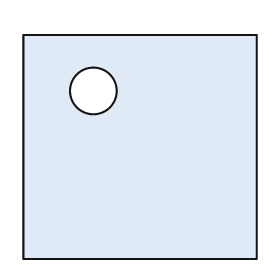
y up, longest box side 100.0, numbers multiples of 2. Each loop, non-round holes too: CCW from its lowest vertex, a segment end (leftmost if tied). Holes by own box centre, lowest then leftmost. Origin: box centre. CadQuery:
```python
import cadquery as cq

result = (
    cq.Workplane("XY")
    .moveTo(-50.0, -48.0)
    .lineTo(50.0, -48.0)
    .lineTo(50.0, 48.0)
    .lineTo(-50.0, 48.0)
    .close()
    .moveTo(-20.0, 24.0)
    .circle(10.0)
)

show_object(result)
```